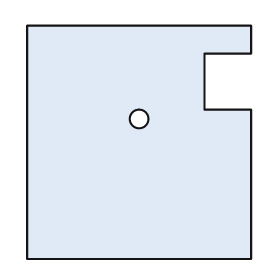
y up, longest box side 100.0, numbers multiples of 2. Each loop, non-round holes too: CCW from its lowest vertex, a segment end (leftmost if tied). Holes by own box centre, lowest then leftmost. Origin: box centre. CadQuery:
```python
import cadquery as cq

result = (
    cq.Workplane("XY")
    .moveTo(-48.0, -50.0)
    .lineTo(48.0, -50.0)
    .lineTo(48.0, 14.0)
    .lineTo(28.0, 14.0)
    .lineTo(28.0, 38.0)
    .lineTo(48.0, 38.0)
    .lineTo(48.0, 50.0)
    .lineTo(-48.0, 50.0)
    .close()
    .moveTo(0.0, 10.0)
    .circle(4.0)
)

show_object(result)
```